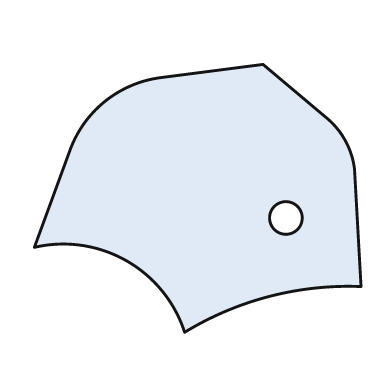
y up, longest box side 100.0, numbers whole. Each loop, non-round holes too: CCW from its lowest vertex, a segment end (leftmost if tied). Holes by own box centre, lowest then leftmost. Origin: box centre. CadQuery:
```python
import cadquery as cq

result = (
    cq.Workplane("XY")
    .moveTo(-4.0, -41.0)
    .threePointArc((22.0, -30.0), (50.0, -27.0))
    .lineTo(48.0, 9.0)
    .threePointArc((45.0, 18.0), (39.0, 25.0))
    .lineTo(20.0, 41.0)
    .lineTo(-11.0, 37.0)
    .threePointArc((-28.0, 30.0), (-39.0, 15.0))
    .lineTo(-50.0, -15.0)
    .threePointArc((-22.0, -19.0), (-4.0, -41.0))
    .close()
    .moveTo(27.0, -6.0)
    .circle(5.0)
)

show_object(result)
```